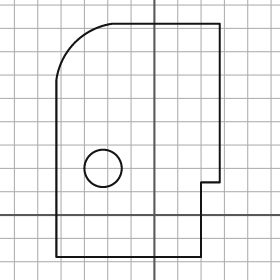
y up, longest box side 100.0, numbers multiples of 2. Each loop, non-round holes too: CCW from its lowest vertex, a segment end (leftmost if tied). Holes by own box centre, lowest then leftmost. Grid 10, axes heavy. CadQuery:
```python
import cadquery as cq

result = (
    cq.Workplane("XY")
    .moveTo(-42.0, -18.0)
    .lineTo(20.0, -18.0)
    .lineTo(20.0, 14.0)
    .lineTo(28.0, 14.0)
    .lineTo(28.0, 82.0)
    .lineTo(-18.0, 82.0)
    .threePointArc((-34.0, 74.0), (-42.0, 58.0))
    .close()
    .moveTo(-22.0, 20.0)
    .circle(8.0)
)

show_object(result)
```